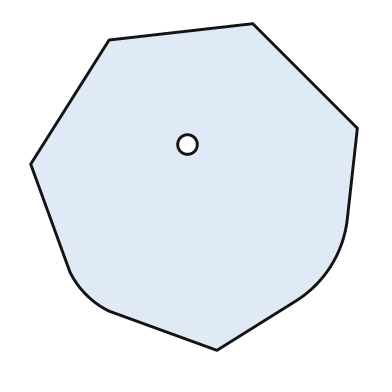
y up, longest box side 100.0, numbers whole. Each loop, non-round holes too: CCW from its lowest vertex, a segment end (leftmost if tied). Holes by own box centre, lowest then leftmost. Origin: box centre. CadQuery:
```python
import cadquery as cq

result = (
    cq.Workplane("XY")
    .moveTo(7.0, -50.0)
    .lineTo(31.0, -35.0)
    .threePointArc((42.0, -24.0), (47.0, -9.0))
    .lineTo(50.0, 18.0)
    .lineTo(18.0, 50.0)
    .lineTo(-26.0, 45.0)
    .lineTo(-50.0, 7.0)
    .lineTo(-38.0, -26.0)
    .threePointArc((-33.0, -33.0), (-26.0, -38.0))
    .close()
    .moveTo(-2.0, 13.0)
    .circle(3.0)
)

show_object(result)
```